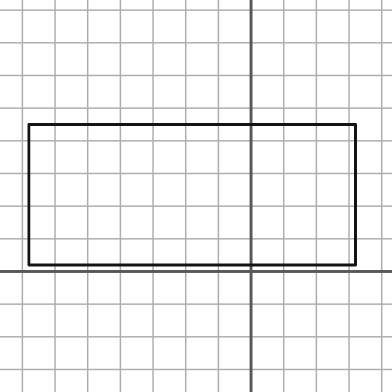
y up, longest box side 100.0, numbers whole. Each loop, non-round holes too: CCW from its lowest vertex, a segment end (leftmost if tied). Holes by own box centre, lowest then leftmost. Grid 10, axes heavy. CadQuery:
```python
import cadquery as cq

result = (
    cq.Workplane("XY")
    .moveTo(-68.0, 2.0)
    .lineTo(32.0, 2.0)
    .lineTo(32.0, 45.0)
    .lineTo(-68.0, 45.0)
    .close()
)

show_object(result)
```